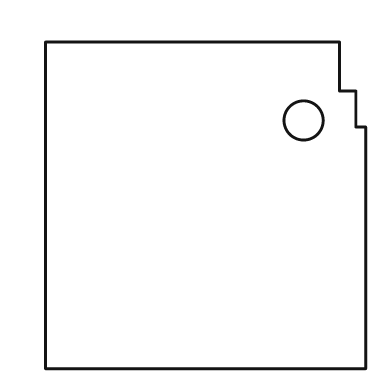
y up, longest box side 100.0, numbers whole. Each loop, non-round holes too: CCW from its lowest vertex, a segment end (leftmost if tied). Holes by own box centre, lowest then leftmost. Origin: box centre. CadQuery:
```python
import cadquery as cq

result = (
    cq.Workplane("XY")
    .moveTo(-49.0, -50.0)
    .lineTo(49.0, -50.0)
    .lineTo(49.0, 24.0)
    .lineTo(46.0, 24.0)
    .lineTo(46.0, 35.0)
    .lineTo(41.0, 35.0)
    .lineTo(41.0, 50.0)
    .lineTo(-49.0, 50.0)
    .close()
    .moveTo(30.0, 26.0)
    .circle(6.0)
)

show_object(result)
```